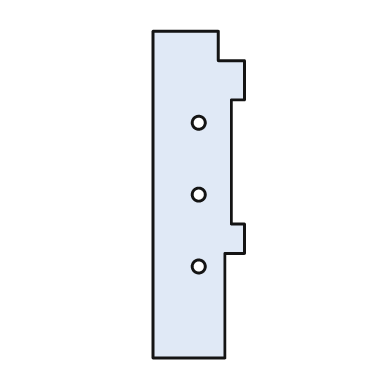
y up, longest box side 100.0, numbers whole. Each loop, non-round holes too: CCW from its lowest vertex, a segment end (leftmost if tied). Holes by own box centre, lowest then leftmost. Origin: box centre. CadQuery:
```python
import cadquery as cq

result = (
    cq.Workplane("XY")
    .moveTo(-14.0, -50.0)
    .lineTo(8.0, -50.0)
    .lineTo(8.0, -18.0)
    .lineTo(14.0, -18.0)
    .lineTo(14.0, -9.0)
    .lineTo(10.0, -9.0)
    .lineTo(10.0, 29.0)
    .lineTo(14.0, 29.0)
    .lineTo(14.0, 41.0)
    .lineTo(6.0, 41.0)
    .lineTo(6.0, 50.0)
    .lineTo(-14.0, 50.0)
    .close()
    .moveTo(0.0, -22.0)
    .circle(2.0)
    .moveTo(0.0, 0.0)
    .circle(2.0)
    .moveTo(0.0, 22.0)
    .circle(2.0)
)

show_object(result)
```